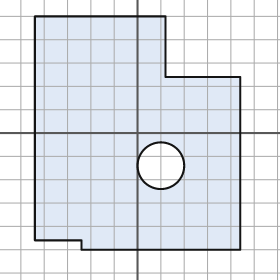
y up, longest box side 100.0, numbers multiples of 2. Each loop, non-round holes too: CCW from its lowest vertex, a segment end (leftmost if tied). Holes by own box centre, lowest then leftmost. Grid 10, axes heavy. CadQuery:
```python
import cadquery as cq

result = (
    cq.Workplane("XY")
    .moveTo(-24.0, -50.0)
    .lineTo(44.0, -50.0)
    .lineTo(44.0, 24.0)
    .lineTo(12.0, 24.0)
    .lineTo(12.0, 50.0)
    .lineTo(-44.0, 50.0)
    .lineTo(-44.0, -46.0)
    .lineTo(-24.0, -46.0)
    .close()
    .moveTo(10.0, -14.0)
    .circle(10.0)
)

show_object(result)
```